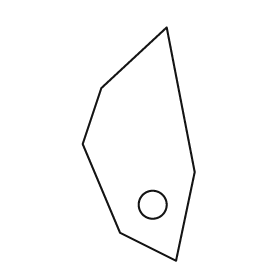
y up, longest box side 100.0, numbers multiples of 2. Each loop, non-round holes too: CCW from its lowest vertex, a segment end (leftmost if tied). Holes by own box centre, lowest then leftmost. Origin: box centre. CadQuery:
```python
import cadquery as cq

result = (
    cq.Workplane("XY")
    .moveTo(16.0, -50.0)
    .lineTo(24.0, -12.0)
    .lineTo(12.0, 50.0)
    .lineTo(-16.0, 24.0)
    .lineTo(-24.0, 0.0)
    .lineTo(-8.0, -38.0)
    .close()
    .moveTo(6.0, -26.0)
    .circle(6.0)
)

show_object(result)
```